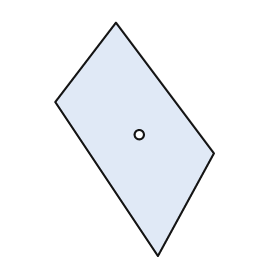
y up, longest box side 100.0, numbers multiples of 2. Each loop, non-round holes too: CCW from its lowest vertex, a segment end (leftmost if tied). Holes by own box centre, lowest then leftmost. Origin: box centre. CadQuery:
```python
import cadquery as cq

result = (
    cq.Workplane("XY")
    .moveTo(10.0, -50.0)
    .lineTo(34.0, -6.0)
    .lineTo(-8.0, 50.0)
    .lineTo(-34.0, 16.0)
    .close()
    .moveTo(2.0, 2.0)
    .circle(2.0)
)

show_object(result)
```